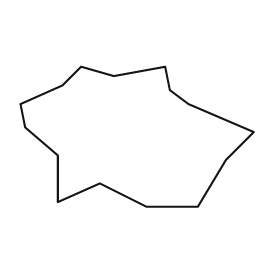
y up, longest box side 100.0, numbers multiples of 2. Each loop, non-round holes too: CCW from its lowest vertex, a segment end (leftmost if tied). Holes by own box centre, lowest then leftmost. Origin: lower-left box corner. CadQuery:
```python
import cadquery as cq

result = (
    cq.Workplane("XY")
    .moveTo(54.0, 0.0)
    .lineTo(76.0, 0.0)
    .lineTo(88.0, 20.0)
    .lineTo(100.0, 32.0)
    .lineTo(72.0, 44.0)
    .lineTo(64.0, 50.0)
    .lineTo(62.0, 60.0)
    .lineTo(40.0, 56.0)
    .lineTo(26.0, 60.0)
    .lineTo(18.0, 52.0)
    .lineTo(0.0, 44.0)
    .lineTo(2.0, 34.0)
    .lineTo(16.0, 22.0)
    .lineTo(16.0, 2.0)
    .lineTo(34.0, 10.0)
    .close()
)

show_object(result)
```